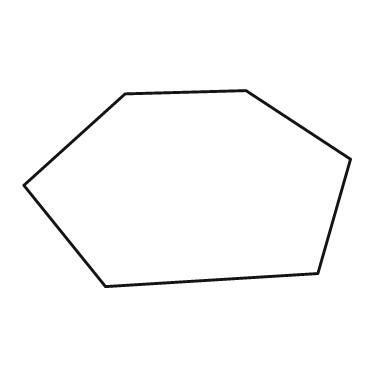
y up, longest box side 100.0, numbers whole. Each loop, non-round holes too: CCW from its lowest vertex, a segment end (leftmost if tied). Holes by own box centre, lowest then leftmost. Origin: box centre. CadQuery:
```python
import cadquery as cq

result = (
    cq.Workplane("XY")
    .moveTo(-25.0, -30.0)
    .lineTo(40.0, -26.0)
    .lineTo(50.0, 9.0)
    .lineTo(18.0, 30.0)
    .lineTo(-19.0, 29.0)
    .lineTo(-50.0, 1.0)
    .close()
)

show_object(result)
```